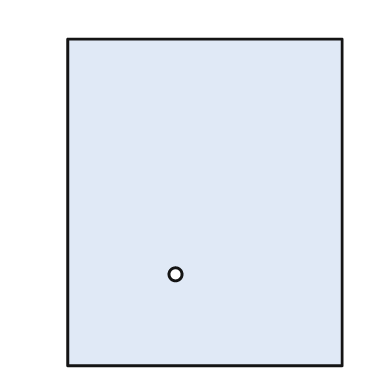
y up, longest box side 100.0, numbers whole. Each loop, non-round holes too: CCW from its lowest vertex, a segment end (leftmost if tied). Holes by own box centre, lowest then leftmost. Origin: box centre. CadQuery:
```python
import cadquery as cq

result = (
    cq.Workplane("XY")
    .moveTo(-42.0, -50.0)
    .lineTo(42.0, -50.0)
    .lineTo(42.0, 50.0)
    .lineTo(-42.0, 50.0)
    .close()
    .moveTo(-9.0, -22.0)
    .circle(2.0)
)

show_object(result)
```